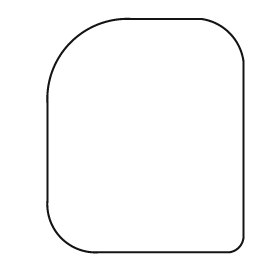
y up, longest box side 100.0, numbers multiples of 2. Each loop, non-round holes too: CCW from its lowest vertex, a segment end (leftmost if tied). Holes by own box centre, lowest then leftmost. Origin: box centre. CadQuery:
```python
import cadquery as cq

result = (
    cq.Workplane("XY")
    .moveTo(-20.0, -50.0)
    .lineTo(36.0, -50.0)
    .threePointArc((40.0, -48.0), (42.0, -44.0))
    .lineTo(42.0, 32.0)
    .threePointArc((36.0, 44.0), (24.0, 50.0))
    .lineTo(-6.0, 50.0)
    .threePointArc((-32.0, 40.0), (-42.0, 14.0))
    .lineTo(-42.0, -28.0)
    .threePointArc((-36.0, -44.0), (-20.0, -50.0))
    .close()
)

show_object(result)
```